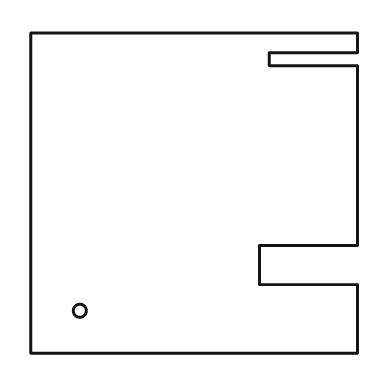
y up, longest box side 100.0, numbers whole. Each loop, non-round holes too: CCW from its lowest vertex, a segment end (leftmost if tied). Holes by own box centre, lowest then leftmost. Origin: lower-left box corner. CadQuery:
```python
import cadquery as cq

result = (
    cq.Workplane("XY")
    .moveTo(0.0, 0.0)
    .lineTo(100.0, 0.0)
    .lineTo(100.0, 21.0)
    .lineTo(70.0, 21.0)
    .lineTo(70.0, 33.0)
    .lineTo(100.0, 33.0)
    .lineTo(100.0, 88.0)
    .lineTo(73.0, 88.0)
    .lineTo(73.0, 92.0)
    .lineTo(100.0, 92.0)
    .lineTo(100.0, 98.0)
    .lineTo(0.0, 98.0)
    .close()
    .moveTo(15.0, 13.0)
    .circle(2.0)
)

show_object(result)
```